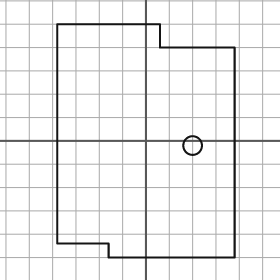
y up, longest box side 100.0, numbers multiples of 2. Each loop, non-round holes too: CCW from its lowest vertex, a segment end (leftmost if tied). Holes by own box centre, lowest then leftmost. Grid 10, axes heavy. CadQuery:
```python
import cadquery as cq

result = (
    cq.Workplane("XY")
    .moveTo(-16.0, -50.0)
    .lineTo(38.0, -50.0)
    .lineTo(38.0, 40.0)
    .lineTo(6.0, 40.0)
    .lineTo(6.0, 50.0)
    .lineTo(-38.0, 50.0)
    .lineTo(-38.0, -44.0)
    .lineTo(-16.0, -44.0)
    .close()
    .moveTo(20.0, -2.0)
    .circle(4.0)
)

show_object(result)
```